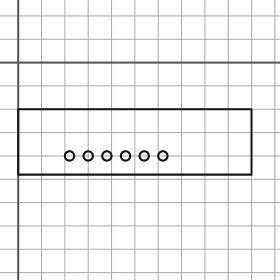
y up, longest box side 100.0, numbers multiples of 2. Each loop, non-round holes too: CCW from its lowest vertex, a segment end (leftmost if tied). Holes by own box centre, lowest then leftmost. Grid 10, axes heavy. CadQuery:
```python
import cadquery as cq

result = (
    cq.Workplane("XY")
    .moveTo(0.0, -48.0)
    .lineTo(100.0, -48.0)
    .lineTo(100.0, -20.0)
    .lineTo(0.0, -20.0)
    .close()
    .moveTo(22.0, -40.0)
    .circle(2.0)
    .moveTo(30.0, -40.0)
    .circle(2.0)
    .moveTo(38.0, -40.0)
    .circle(2.0)
    .moveTo(46.0, -40.0)
    .circle(2.0)
    .moveTo(54.0, -40.0)
    .circle(2.0)
    .moveTo(62.0, -40.0)
    .circle(2.0)
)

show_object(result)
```